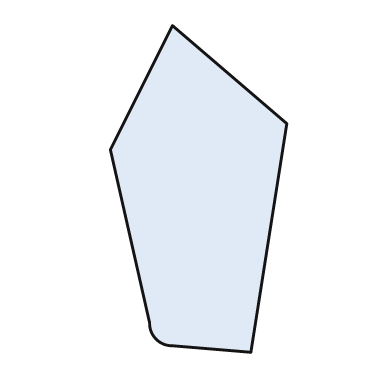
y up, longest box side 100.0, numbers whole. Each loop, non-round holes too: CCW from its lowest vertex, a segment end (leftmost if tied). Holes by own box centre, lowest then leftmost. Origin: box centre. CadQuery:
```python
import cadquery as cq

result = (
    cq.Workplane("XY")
    .moveTo(16.0, -50.0)
    .lineTo(27.0, 20.0)
    .lineTo(-8.0, 50.0)
    .lineTo(-27.0, 12.0)
    .lineTo(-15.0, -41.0)
    .threePointArc((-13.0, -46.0), (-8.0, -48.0))
    .close()
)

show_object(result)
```